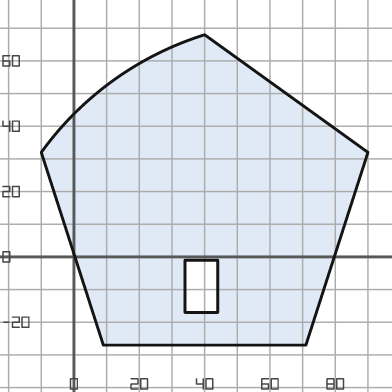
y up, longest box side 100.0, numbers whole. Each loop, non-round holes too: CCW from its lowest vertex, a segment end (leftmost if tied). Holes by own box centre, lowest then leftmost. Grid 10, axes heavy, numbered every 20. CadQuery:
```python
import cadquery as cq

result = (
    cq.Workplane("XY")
    .moveTo(9.0, -27.0)
    .lineTo(71.0, -27.0)
    .lineTo(90.0, 32.0)
    .lineTo(40.0, 68.0)
    .threePointArc((12.0, 54.0), (-10.0, 32.0))
    .close()
    .moveTo(34.0, -17.0)
    .lineTo(44.0, -17.0)
    .lineTo(44.0, -1.0)
    .lineTo(34.0, -1.0)
    .close()
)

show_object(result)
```